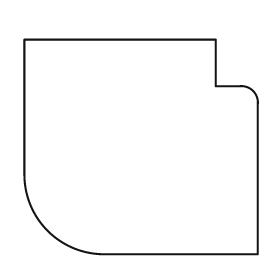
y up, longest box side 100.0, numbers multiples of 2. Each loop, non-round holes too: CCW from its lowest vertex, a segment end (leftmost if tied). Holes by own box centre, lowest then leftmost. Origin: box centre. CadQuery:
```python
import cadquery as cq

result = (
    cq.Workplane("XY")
    .moveTo(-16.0, -46.0)
    .lineTo(50.0, -46.0)
    .lineTo(50.0, 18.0)
    .threePointArc((48.0, 24.0), (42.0, 26.0))
    .lineTo(32.0, 26.0)
    .lineTo(32.0, 46.0)
    .lineTo(-50.0, 46.0)
    .lineTo(-50.0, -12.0)
    .threePointArc((-40.0, -36.0), (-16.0, -46.0))
    .close()
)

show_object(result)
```